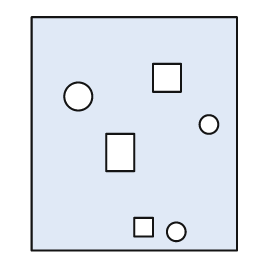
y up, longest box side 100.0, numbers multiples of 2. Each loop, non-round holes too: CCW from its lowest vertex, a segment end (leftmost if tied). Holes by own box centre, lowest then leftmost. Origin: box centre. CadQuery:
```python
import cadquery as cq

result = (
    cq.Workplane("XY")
    .moveTo(-44.0, -50.0)
    .lineTo(44.0, -50.0)
    .lineTo(44.0, 50.0)
    .lineTo(-44.0, 50.0)
    .close()
    .moveTo(18.0, -42.0)
    .circle(4.0)
    .moveTo(0.0, -44.0)
    .lineTo(8.0, -44.0)
    .lineTo(8.0, -36.0)
    .lineTo(0.0, -36.0)
    .close()
    .moveTo(-12.0, -16.0)
    .lineTo(0.0, -16.0)
    .lineTo(0.0, 0.0)
    .lineTo(-12.0, 0.0)
    .close()
    .moveTo(32.0, 4.0)
    .circle(4.0)
    .moveTo(-24.0, 16.0)
    .circle(6.0)
    .moveTo(8.0, 18.0)
    .lineTo(20.0, 18.0)
    .lineTo(20.0, 30.0)
    .lineTo(8.0, 30.0)
    .close()
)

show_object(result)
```